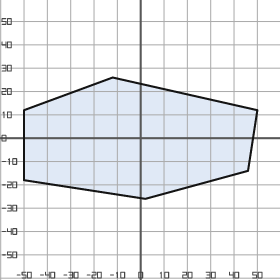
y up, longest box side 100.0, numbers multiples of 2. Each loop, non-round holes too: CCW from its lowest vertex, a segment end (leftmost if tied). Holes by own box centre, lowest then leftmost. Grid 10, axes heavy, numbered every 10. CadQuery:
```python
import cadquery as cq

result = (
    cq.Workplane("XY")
    .moveTo(2.0, -26.0)
    .lineTo(46.0, -14.0)
    .lineTo(50.0, 12.0)
    .lineTo(-12.0, 26.0)
    .lineTo(-50.0, 12.0)
    .lineTo(-50.0, -18.0)
    .close()
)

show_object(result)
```